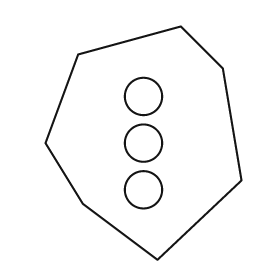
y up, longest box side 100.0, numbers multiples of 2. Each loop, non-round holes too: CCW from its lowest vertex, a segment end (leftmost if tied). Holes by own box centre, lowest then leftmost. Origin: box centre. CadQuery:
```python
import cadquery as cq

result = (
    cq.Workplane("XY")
    .moveTo(6.0, -50.0)
    .lineTo(42.0, -16.0)
    .lineTo(34.0, 32.0)
    .lineTo(16.0, 50.0)
    .lineTo(-28.0, 38.0)
    .lineTo(-42.0, 0.0)
    .lineTo(-26.0, -26.0)
    .close()
    .moveTo(0.0, -20.0)
    .circle(8.0)
    .moveTo(0.0, 0.0)
    .circle(8.0)
    .moveTo(0.0, 20.0)
    .circle(8.0)
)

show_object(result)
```